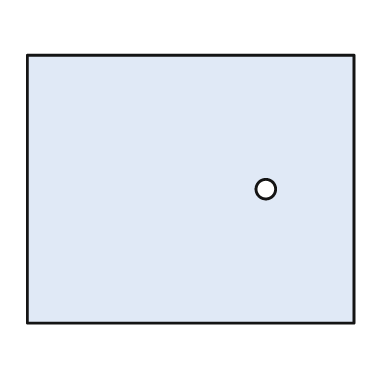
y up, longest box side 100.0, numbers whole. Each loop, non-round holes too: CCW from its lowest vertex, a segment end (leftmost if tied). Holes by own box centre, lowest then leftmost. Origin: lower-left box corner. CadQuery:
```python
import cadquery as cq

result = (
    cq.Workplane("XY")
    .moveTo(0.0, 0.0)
    .lineTo(100.0, 0.0)
    .lineTo(100.0, 82.0)
    .lineTo(0.0, 82.0)
    .close()
    .moveTo(73.0, 41.0)
    .circle(3.0)
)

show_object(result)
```